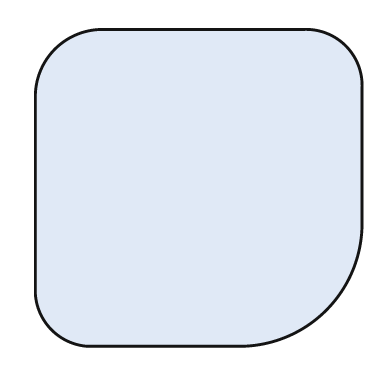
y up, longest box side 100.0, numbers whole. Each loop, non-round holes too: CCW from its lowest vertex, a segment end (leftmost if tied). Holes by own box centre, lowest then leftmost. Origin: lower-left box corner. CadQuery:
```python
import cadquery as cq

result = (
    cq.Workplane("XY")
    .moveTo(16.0, 0.0)
    .lineTo(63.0, 0.0)
    .threePointArc((89.0, 11.0), (100.0, 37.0))
    .lineTo(100.0, 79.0)
    .threePointArc((95.0, 92.0), (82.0, 97.0))
    .lineTo(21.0, 97.0)
    .threePointArc((6.0, 91.0), (0.0, 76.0))
    .lineTo(0.0, 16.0)
    .threePointArc((5.0, 5.0), (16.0, 0.0))
    .close()
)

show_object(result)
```